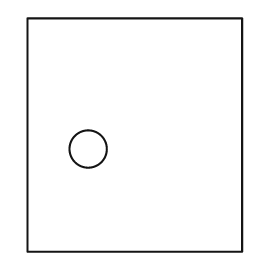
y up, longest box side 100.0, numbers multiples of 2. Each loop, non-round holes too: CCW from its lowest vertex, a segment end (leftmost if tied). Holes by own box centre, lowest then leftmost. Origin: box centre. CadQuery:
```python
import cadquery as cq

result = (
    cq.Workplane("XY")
    .moveTo(-46.0, -50.0)
    .lineTo(46.0, -50.0)
    .lineTo(46.0, 50.0)
    .lineTo(-46.0, 50.0)
    .close()
    .moveTo(-20.0, -6.0)
    .circle(8.0)
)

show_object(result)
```